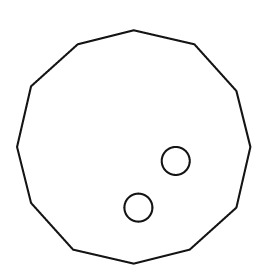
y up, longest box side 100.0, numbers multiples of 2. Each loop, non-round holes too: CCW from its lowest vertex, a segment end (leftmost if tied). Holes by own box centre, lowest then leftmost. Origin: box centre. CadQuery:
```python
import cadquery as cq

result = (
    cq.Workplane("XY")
    .moveTo(0.0, -50.0)
    .lineTo(24.0, -44.0)
    .lineTo(44.0, -26.0)
    .lineTo(50.0, 0.0)
    .lineTo(44.0, 24.0)
    .lineTo(26.0, 44.0)
    .lineTo(0.0, 50.0)
    .lineTo(-24.0, 44.0)
    .lineTo(-44.0, 26.0)
    .lineTo(-50.0, 0.0)
    .lineTo(-44.0, -24.0)
    .lineTo(-26.0, -44.0)
    .close()
    .moveTo(2.0, -26.0)
    .circle(6.0)
    .moveTo(18.0, -6.0)
    .circle(6.0)
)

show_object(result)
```